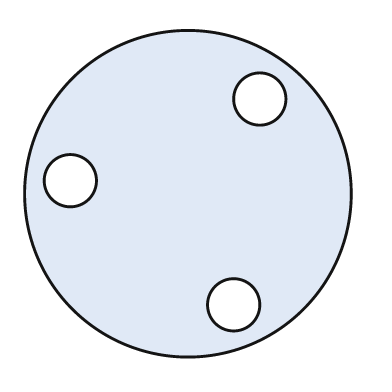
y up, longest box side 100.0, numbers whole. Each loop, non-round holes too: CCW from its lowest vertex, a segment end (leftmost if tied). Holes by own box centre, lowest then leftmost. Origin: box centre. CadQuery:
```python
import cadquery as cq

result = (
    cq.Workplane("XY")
    .moveTo(0.0, 0.0)
    .circle(50.0)
    .moveTo(14.0, -34.0)
    .circle(8.0)
    .moveTo(-36.0, 4.0)
    .circle(8.0)
    .moveTo(22.0, 29.0)
    .circle(8.0)
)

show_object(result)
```